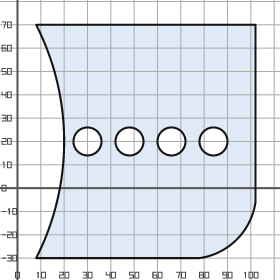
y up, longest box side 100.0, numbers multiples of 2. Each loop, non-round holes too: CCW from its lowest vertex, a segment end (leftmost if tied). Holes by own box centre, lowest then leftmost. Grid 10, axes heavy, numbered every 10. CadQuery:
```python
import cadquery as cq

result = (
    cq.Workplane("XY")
    .moveTo(8.0, -30.0)
    .lineTo(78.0, -30.0)
    .threePointArc((94.0, -22.0), (102.0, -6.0))
    .lineTo(102.0, 70.0)
    .lineTo(8.0, 70.0)
    .threePointArc((20.0, 20.0), (8.0, -30.0))
    .close()
    .moveTo(30.0, 20.0)
    .circle(6.0)
    .moveTo(48.0, 20.0)
    .circle(6.0)
    .moveTo(66.0, 20.0)
    .circle(6.0)
    .moveTo(84.0, 20.0)
    .circle(6.0)
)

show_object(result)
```